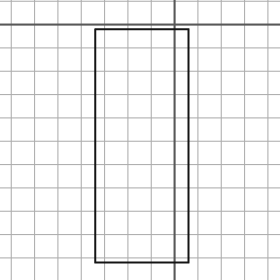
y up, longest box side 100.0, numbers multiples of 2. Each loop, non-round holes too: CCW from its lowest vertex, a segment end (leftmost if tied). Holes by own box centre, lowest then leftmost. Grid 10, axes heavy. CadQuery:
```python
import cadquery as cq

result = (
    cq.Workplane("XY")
    .moveTo(-34.0, -102.0)
    .lineTo(6.0, -102.0)
    .lineTo(6.0, -2.0)
    .lineTo(-34.0, -2.0)
    .close()
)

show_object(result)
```